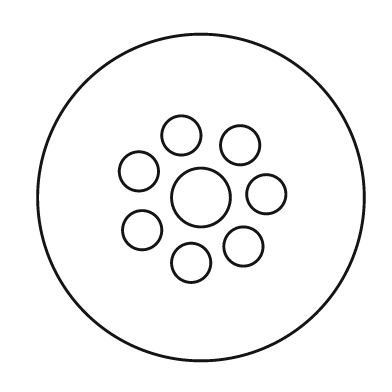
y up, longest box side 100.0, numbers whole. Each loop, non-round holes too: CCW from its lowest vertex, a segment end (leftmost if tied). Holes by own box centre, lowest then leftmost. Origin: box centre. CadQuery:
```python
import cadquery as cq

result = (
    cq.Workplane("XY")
    .moveTo(0.0, 0.0)
    .circle(50.0)
    .moveTo(-3.0, -20.0)
    .circle(6.0)
    .moveTo(13.0, -15.0)
    .circle(6.0)
    .moveTo(-18.0, -10.0)
    .circle(6.0)
    .moveTo(0.0, 0.0)
    .circle(9.0)
    .moveTo(20.0, 1.0)
    .circle(6.0)
    .moveTo(-19.0, 8.0)
    .circle(6.0)
    .moveTo(12.0, 16.0)
    .circle(6.0)
    .moveTo(-6.0, 19.0)
    .circle(6.0)
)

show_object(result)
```